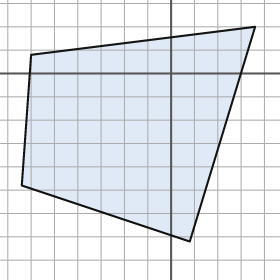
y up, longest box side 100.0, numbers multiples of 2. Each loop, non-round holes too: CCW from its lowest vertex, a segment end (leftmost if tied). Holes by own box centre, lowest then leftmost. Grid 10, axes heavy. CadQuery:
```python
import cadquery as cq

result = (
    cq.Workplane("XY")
    .moveTo(8.0, -72.0)
    .lineTo(36.0, 20.0)
    .lineTo(-60.0, 8.0)
    .lineTo(-64.0, -48.0)
    .close()
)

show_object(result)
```